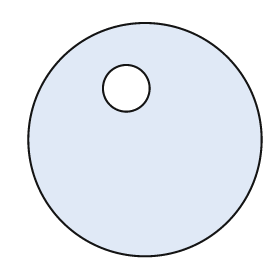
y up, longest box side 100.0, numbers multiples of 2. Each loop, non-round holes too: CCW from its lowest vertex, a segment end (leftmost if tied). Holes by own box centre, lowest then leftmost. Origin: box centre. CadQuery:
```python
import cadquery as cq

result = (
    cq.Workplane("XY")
    .moveTo(0.0, 0.0)
    .circle(50.0)
    .moveTo(-8.0, 22.0)
    .circle(10.0)
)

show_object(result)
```